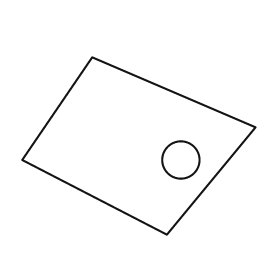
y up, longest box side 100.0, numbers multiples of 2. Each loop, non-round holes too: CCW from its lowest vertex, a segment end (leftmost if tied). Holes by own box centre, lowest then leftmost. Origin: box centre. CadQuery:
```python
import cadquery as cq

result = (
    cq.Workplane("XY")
    .moveTo(12.0, -38.0)
    .lineTo(50.0, 8.0)
    .lineTo(-20.0, 38.0)
    .lineTo(-50.0, -6.0)
    .close()
    .moveTo(18.0, -6.0)
    .circle(8.0)
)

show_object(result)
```